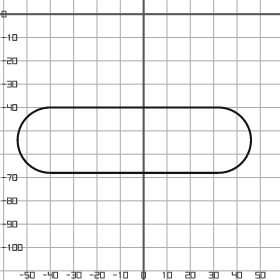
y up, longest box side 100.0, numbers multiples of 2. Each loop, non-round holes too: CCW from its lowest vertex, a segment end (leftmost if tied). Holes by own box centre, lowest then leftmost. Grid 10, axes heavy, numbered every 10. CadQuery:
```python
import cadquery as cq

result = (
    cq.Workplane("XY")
    .moveTo(-40.0, -68.0)
    .lineTo(32.0, -68.0)
    .threePointArc((46.0, -54.0), (32.0, -40.0))
    .lineTo(-40.0, -40.0)
    .threePointArc((-54.0, -54.0), (-40.0, -68.0))
    .close()
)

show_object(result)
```